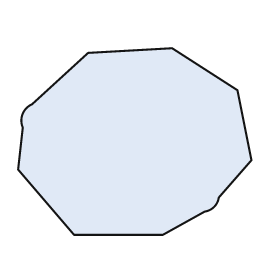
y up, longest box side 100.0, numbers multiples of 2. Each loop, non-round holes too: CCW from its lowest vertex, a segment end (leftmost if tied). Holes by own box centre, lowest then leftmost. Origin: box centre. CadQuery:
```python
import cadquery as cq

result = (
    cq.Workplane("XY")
    .moveTo(-26.0, -40.0)
    .lineTo(12.0, -40.0)
    .lineTo(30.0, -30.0)
    .threePointArc((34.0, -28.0), (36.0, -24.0))
    .lineTo(50.0, -8.0)
    .lineTo(44.0, 22.0)
    .lineTo(16.0, 40.0)
    .lineTo(-20.0, 38.0)
    .lineTo(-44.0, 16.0)
    .threePointArc((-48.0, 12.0), (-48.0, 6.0))
    .lineTo(-50.0, -12.0)
    .close()
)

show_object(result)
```